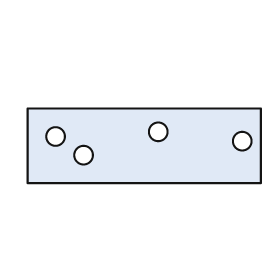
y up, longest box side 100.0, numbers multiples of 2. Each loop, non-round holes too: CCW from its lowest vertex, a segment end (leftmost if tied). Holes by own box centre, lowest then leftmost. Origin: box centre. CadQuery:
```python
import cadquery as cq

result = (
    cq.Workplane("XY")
    .moveTo(-50.0, -16.0)
    .lineTo(50.0, -16.0)
    .lineTo(50.0, 16.0)
    .lineTo(-50.0, 16.0)
    .close()
    .moveTo(-26.0, -4.0)
    .circle(4.0)
    .moveTo(42.0, 2.0)
    .circle(4.0)
    .moveTo(-38.0, 4.0)
    .circle(4.0)
    .moveTo(6.0, 6.0)
    .circle(4.0)
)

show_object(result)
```